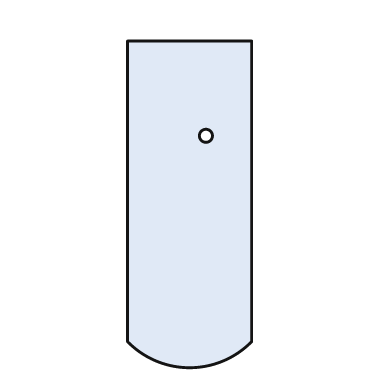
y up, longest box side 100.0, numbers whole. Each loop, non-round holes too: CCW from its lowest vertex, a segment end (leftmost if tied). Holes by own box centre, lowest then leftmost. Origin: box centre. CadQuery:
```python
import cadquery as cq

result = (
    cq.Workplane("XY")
    .moveTo(-19.0, -42.0)
    .threePointArc((0.0, -50.0), (19.0, -42.0))
    .lineTo(19.0, 50.0)
    .lineTo(-19.0, 50.0)
    .close()
    .moveTo(5.0, 21.0)
    .circle(2.0)
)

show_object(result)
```